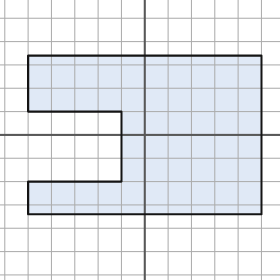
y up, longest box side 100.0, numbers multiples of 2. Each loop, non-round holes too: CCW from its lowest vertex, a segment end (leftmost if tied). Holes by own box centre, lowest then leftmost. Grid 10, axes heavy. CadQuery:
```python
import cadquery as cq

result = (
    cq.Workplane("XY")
    .moveTo(-50.0, -34.0)
    .lineTo(50.0, -34.0)
    .lineTo(50.0, 34.0)
    .lineTo(-50.0, 34.0)
    .lineTo(-50.0, 10.0)
    .lineTo(-10.0, 10.0)
    .lineTo(-10.0, -20.0)
    .lineTo(-50.0, -20.0)
    .close()
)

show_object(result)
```